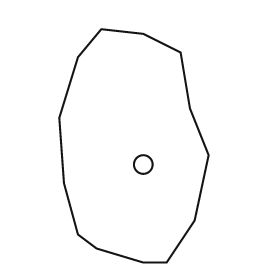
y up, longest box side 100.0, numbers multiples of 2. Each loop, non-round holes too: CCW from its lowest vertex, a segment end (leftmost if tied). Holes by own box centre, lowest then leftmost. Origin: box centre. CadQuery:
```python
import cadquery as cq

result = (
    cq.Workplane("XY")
    .moveTo(4.0, -50.0)
    .lineTo(14.0, -50.0)
    .lineTo(26.0, -32.0)
    .lineTo(32.0, -4.0)
    .lineTo(24.0, 16.0)
    .lineTo(20.0, 40.0)
    .lineTo(4.0, 48.0)
    .lineTo(-14.0, 50.0)
    .lineTo(-24.0, 38.0)
    .lineTo(-32.0, 12.0)
    .lineTo(-30.0, -16.0)
    .lineTo(-24.0, -38.0)
    .lineTo(-16.0, -44.0)
    .close()
    .moveTo(4.0, -8.0)
    .circle(4.0)
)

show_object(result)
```